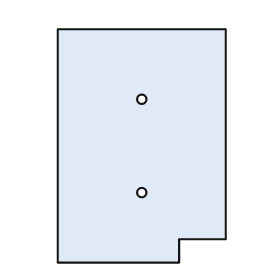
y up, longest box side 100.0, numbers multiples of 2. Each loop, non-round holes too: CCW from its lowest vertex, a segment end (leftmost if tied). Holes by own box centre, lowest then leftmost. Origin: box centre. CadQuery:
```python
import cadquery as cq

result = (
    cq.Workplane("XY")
    .moveTo(-36.0, -50.0)
    .lineTo(16.0, -50.0)
    .lineTo(16.0, -40.0)
    .lineTo(36.0, -40.0)
    .lineTo(36.0, 50.0)
    .lineTo(-36.0, 50.0)
    .close()
    .moveTo(0.0, -20.0)
    .circle(2.0)
    .moveTo(0.0, 20.0)
    .circle(2.0)
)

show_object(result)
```